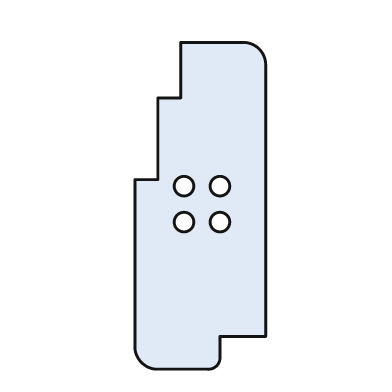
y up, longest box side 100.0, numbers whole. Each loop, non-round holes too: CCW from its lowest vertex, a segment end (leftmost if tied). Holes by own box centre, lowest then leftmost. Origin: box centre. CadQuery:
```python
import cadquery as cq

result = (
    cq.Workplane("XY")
    .moveTo(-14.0, -50.0)
    .lineTo(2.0, -50.0)
    .threePointArc((5.0, -49.0), (6.0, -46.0))
    .lineTo(6.0, -40.0)
    .lineTo(20.0, -40.0)
    .lineTo(20.0, 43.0)
    .threePointArc((18.0, 48.0), (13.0, 50.0))
    .lineTo(-6.0, 50.0)
    .lineTo(-6.0, 33.0)
    .lineTo(-13.0, 33.0)
    .lineTo(-13.0, 8.0)
    .lineTo(-20.0, 8.0)
    .lineTo(-20.0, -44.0)
    .threePointArc((-18.0, -48.0), (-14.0, -50.0))
    .close()
    .moveTo(-5.0, -5.0)
    .circle(3.0)
    .moveTo(6.0, -5.0)
    .circle(3.0)
    .moveTo(-5.0, 6.0)
    .circle(3.0)
    .moveTo(6.0, 6.0)
    .circle(3.0)
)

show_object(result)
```